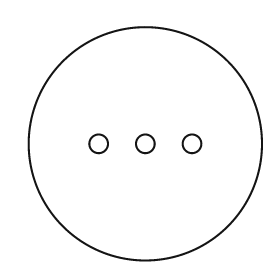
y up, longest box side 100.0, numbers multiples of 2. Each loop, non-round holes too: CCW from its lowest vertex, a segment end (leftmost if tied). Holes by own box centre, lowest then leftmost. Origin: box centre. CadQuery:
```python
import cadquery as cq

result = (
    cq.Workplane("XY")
    .moveTo(0.0, 0.0)
    .circle(50.0)
    .moveTo(-20.0, 0.0)
    .circle(4.0)
    .moveTo(0.0, 0.0)
    .circle(4.0)
    .moveTo(20.0, 0.0)
    .circle(4.0)
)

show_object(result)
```